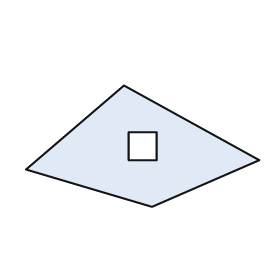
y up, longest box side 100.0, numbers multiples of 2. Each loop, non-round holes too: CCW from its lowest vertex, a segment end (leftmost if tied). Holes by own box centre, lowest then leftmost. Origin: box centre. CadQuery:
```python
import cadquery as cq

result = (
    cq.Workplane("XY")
    .moveTo(4.0, -26.0)
    .lineTo(50.0, -6.0)
    .lineTo(-8.0, 26.0)
    .lineTo(-50.0, -10.0)
    .close()
    .moveTo(-6.0, -6.0)
    .lineTo(6.0, -6.0)
    .lineTo(6.0, 6.0)
    .lineTo(-6.0, 6.0)
    .close()
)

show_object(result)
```